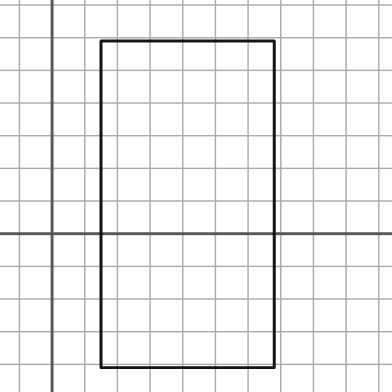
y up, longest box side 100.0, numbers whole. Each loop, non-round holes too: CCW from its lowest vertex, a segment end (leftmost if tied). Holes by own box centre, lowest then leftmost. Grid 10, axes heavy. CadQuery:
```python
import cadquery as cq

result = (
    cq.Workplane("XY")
    .moveTo(15.0, -41.0)
    .lineTo(68.0, -41.0)
    .lineTo(68.0, 59.0)
    .lineTo(15.0, 59.0)
    .close()
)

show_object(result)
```